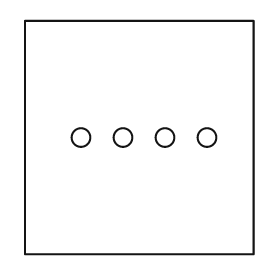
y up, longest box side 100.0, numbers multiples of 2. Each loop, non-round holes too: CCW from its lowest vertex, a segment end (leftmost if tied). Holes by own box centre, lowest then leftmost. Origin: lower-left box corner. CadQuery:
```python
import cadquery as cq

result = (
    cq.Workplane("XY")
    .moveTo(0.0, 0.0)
    .lineTo(98.0, 0.0)
    .lineTo(98.0, 100.0)
    .lineTo(0.0, 100.0)
    .close()
    .moveTo(24.0, 50.0)
    .circle(4.0)
    .moveTo(42.0, 50.0)
    .circle(4.0)
    .moveTo(60.0, 50.0)
    .circle(4.0)
    .moveTo(78.0, 50.0)
    .circle(4.0)
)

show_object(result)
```